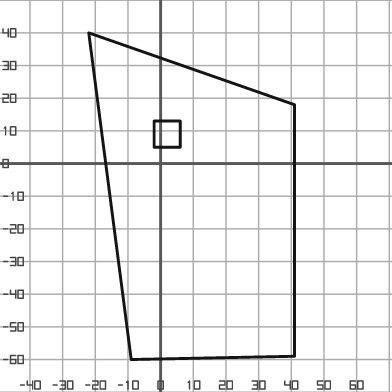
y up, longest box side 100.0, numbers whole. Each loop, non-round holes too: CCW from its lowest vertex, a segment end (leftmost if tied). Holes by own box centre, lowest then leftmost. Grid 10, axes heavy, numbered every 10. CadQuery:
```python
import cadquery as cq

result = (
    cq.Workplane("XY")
    .moveTo(-9.0, -60.0)
    .lineTo(41.0, -59.0)
    .lineTo(41.0, 18.0)
    .lineTo(-22.0, 40.0)
    .close()
    .moveTo(-2.0, 5.0)
    .lineTo(6.0, 5.0)
    .lineTo(6.0, 13.0)
    .lineTo(-2.0, 13.0)
    .close()
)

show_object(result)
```